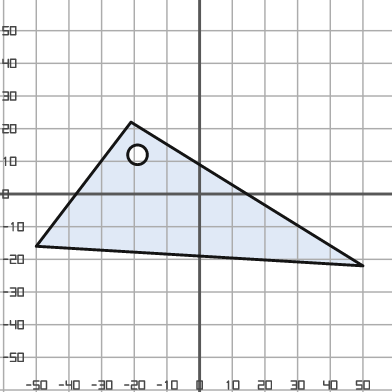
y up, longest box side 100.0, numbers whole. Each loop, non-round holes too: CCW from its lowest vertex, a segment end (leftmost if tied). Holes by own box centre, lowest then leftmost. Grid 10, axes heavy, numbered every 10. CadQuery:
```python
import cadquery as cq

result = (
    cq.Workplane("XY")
    .moveTo(50.0, -22.0)
    .lineTo(-21.0, 22.0)
    .lineTo(-50.0, -16.0)
    .close()
    .moveTo(-19.0, 12.0)
    .circle(3.0)
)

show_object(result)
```